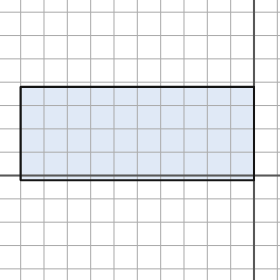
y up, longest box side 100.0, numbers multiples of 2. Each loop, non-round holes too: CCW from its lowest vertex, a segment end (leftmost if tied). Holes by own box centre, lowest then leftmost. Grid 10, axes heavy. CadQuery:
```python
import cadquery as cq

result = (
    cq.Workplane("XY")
    .moveTo(-100.0, -2.0)
    .lineTo(0.0, -2.0)
    .lineTo(0.0, 38.0)
    .lineTo(-100.0, 38.0)
    .close()
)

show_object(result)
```